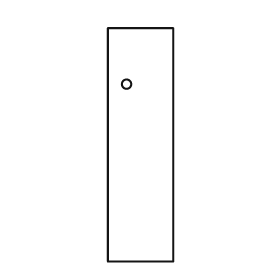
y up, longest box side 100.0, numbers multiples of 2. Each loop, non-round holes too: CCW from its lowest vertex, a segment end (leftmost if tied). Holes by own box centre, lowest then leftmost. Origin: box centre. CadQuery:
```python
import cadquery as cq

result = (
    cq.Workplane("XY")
    .moveTo(-14.0, -50.0)
    .lineTo(14.0, -50.0)
    .lineTo(14.0, 50.0)
    .lineTo(-14.0, 50.0)
    .close()
    .moveTo(-6.0, 26.0)
    .circle(2.0)
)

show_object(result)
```